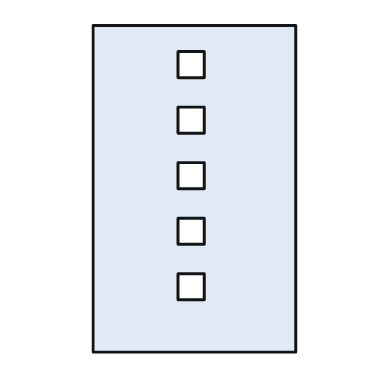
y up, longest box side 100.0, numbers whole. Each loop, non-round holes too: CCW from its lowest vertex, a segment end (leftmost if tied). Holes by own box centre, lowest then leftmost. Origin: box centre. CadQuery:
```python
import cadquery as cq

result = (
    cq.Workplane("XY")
    .moveTo(-31.0, -50.0)
    .lineTo(31.0, -50.0)
    .lineTo(31.0, 50.0)
    .lineTo(-31.0, 50.0)
    .close()
    .moveTo(-5.0, -34.0)
    .lineTo(3.0, -34.0)
    .lineTo(3.0, -26.0)
    .lineTo(-5.0, -26.0)
    .close()
    .moveTo(-5.0, -17.0)
    .lineTo(3.0, -17.0)
    .lineTo(3.0, -9.0)
    .lineTo(-5.0, -9.0)
    .close()
    .moveTo(-5.0, 0.0)
    .lineTo(3.0, 0.0)
    .lineTo(3.0, 8.0)
    .lineTo(-5.0, 8.0)
    .close()
    .moveTo(-5.0, 17.0)
    .lineTo(3.0, 17.0)
    .lineTo(3.0, 25.0)
    .lineTo(-5.0, 25.0)
    .close()
    .moveTo(-5.0, 34.0)
    .lineTo(3.0, 34.0)
    .lineTo(3.0, 42.0)
    .lineTo(-5.0, 42.0)
    .close()
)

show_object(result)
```